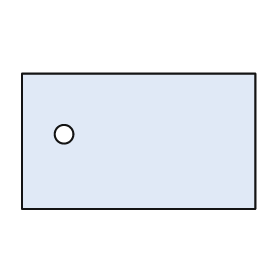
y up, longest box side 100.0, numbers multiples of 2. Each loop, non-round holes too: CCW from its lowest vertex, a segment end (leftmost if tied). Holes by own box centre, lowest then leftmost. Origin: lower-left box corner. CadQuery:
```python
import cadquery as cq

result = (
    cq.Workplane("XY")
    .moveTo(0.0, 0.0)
    .lineTo(100.0, 0.0)
    .lineTo(100.0, 58.0)
    .lineTo(0.0, 58.0)
    .close()
    .moveTo(18.0, 32.0)
    .circle(4.0)
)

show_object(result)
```